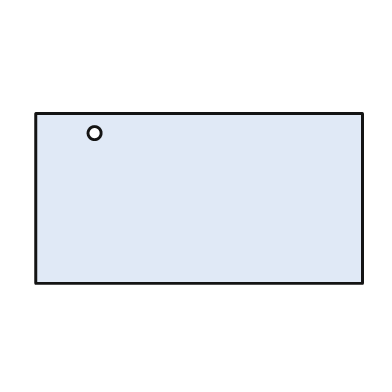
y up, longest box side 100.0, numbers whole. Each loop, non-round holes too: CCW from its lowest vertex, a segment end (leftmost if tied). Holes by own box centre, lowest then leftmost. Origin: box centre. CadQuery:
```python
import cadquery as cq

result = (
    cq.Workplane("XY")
    .moveTo(-50.0, -26.0)
    .lineTo(50.0, -26.0)
    .lineTo(50.0, 26.0)
    .lineTo(-50.0, 26.0)
    .close()
    .moveTo(-32.0, 20.0)
    .circle(2.0)
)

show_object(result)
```